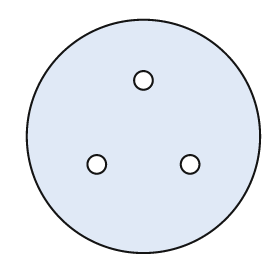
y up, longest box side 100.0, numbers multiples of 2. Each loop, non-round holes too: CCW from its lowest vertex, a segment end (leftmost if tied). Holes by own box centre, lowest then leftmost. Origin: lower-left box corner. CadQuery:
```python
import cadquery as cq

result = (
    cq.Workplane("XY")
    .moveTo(50.0, 50.0)
    .circle(50.0)
    .moveTo(30.0, 38.0)
    .circle(4.0)
    .moveTo(70.0, 38.0)
    .circle(4.0)
    .moveTo(50.0, 74.0)
    .circle(4.0)
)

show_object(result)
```